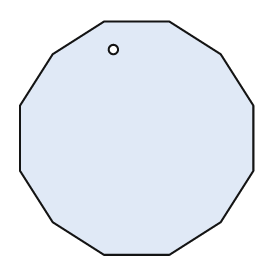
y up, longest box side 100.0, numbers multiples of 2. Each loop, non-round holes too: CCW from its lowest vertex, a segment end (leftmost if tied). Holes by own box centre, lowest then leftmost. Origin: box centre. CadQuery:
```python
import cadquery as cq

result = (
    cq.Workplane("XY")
    .moveTo(-14.0, -50.0)
    .lineTo(14.0, -50.0)
    .lineTo(36.0, -36.0)
    .lineTo(50.0, -14.0)
    .lineTo(50.0, 14.0)
    .lineTo(36.0, 36.0)
    .lineTo(14.0, 50.0)
    .lineTo(-14.0, 50.0)
    .lineTo(-36.0, 36.0)
    .lineTo(-50.0, 14.0)
    .lineTo(-50.0, -14.0)
    .lineTo(-36.0, -36.0)
    .close()
    .moveTo(-10.0, 38.0)
    .circle(2.0)
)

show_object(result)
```